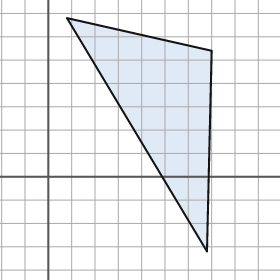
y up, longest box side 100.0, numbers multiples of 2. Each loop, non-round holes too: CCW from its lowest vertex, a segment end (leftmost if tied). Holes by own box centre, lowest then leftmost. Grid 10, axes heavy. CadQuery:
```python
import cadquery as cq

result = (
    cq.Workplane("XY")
    .moveTo(68.0, -32.0)
    .lineTo(70.0, 54.0)
    .lineTo(8.0, 68.0)
    .close()
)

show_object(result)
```